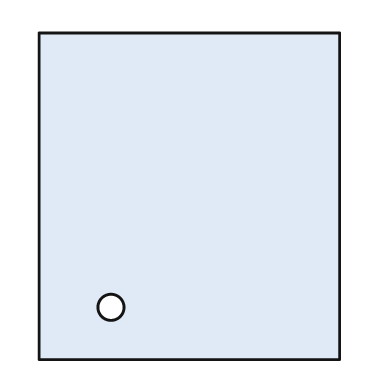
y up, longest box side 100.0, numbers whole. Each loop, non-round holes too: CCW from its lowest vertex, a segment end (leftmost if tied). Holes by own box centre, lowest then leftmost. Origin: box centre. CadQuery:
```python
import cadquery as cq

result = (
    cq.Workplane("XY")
    .moveTo(-46.0, -50.0)
    .lineTo(46.0, -50.0)
    .lineTo(46.0, 50.0)
    .lineTo(-46.0, 50.0)
    .close()
    .moveTo(-24.0, -34.0)
    .circle(4.0)
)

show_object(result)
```